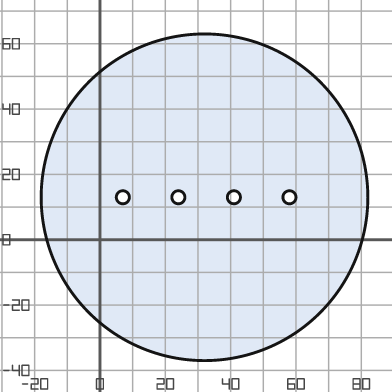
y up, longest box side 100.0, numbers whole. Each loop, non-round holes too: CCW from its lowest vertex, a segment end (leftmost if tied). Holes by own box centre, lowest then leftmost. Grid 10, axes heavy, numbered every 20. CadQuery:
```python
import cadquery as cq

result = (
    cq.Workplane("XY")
    .moveTo(32.0, 13.0)
    .circle(50.0)
    .moveTo(7.0, 13.0)
    .circle(2.0)
    .moveTo(24.0, 13.0)
    .circle(2.0)
    .moveTo(41.0, 13.0)
    .circle(2.0)
    .moveTo(58.0, 13.0)
    .circle(2.0)
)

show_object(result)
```